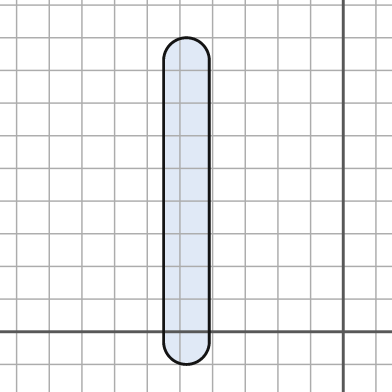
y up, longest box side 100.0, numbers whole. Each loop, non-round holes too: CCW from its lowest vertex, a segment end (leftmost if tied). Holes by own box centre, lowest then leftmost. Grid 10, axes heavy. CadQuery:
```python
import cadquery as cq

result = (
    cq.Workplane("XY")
    .moveTo(-55.0, -3.0)
    .threePointArc((-48.0, -10.0), (-41.0, -3.0))
    .lineTo(-41.0, 83.0)
    .threePointArc((-48.0, 90.0), (-55.0, 83.0))
    .close()
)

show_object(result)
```